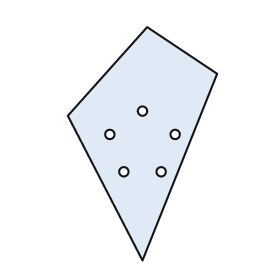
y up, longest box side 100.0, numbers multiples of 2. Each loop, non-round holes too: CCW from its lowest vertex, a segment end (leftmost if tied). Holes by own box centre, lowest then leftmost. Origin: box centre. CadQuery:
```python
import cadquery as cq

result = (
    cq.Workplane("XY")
    .moveTo(0.0, -50.0)
    .lineTo(32.0, 30.0)
    .lineTo(2.0, 50.0)
    .lineTo(-32.0, 12.0)
    .close()
    .moveTo(-8.0, -12.0)
    .circle(2.0)
    .moveTo(8.0, -12.0)
    .circle(2.0)
    .moveTo(-14.0, 4.0)
    .circle(2.0)
    .moveTo(14.0, 4.0)
    .circle(2.0)
    .moveTo(0.0, 14.0)
    .circle(2.0)
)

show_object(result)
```